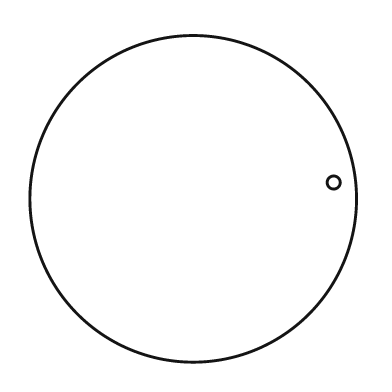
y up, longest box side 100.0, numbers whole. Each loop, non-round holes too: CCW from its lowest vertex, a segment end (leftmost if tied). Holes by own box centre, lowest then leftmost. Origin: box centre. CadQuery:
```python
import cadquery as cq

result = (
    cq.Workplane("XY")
    .moveTo(0.0, 0.0)
    .circle(50.0)
    .moveTo(43.0, 5.0)
    .circle(2.0)
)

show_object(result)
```